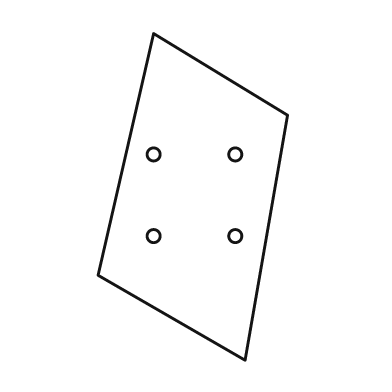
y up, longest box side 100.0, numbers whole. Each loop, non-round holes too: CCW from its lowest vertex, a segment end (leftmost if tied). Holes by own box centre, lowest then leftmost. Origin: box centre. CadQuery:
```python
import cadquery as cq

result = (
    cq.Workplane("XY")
    .moveTo(16.0, -50.0)
    .lineTo(29.0, 25.0)
    .lineTo(-12.0, 50.0)
    .lineTo(-29.0, -24.0)
    .close()
    .moveTo(-12.0, -12.0)
    .circle(2.0)
    .moveTo(13.0, -12.0)
    .circle(2.0)
    .moveTo(-12.0, 13.0)
    .circle(2.0)
    .moveTo(13.0, 13.0)
    .circle(2.0)
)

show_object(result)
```